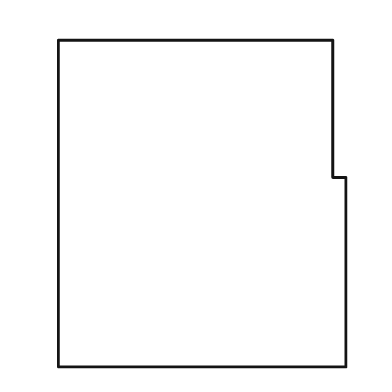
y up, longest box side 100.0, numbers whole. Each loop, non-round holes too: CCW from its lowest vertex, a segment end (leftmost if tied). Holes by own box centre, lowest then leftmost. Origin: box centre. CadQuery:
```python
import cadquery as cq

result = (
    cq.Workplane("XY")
    .moveTo(-44.0, -50.0)
    .lineTo(44.0, -50.0)
    .lineTo(44.0, 8.0)
    .lineTo(40.0, 8.0)
    .lineTo(40.0, 50.0)
    .lineTo(-44.0, 50.0)
    .close()
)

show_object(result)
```